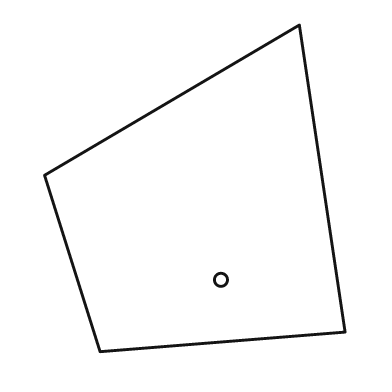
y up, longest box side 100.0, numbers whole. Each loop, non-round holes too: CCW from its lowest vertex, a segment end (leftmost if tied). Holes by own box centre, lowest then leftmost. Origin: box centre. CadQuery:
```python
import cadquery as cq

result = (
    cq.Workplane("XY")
    .moveTo(-29.0, -50.0)
    .lineTo(46.0, -44.0)
    .lineTo(32.0, 50.0)
    .lineTo(-46.0, 4.0)
    .close()
    .moveTo(8.0, -28.0)
    .circle(2.0)
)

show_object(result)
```